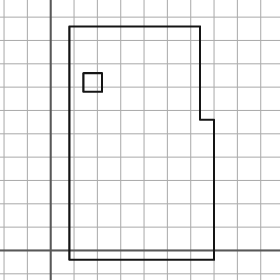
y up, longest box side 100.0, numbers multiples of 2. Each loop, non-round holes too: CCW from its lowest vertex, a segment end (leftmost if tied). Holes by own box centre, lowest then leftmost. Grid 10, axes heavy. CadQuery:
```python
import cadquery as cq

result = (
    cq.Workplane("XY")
    .moveTo(8.0, -4.0)
    .lineTo(70.0, -4.0)
    .lineTo(70.0, 56.0)
    .lineTo(64.0, 56.0)
    .lineTo(64.0, 96.0)
    .lineTo(8.0, 96.0)
    .close()
    .moveTo(14.0, 68.0)
    .lineTo(22.0, 68.0)
    .lineTo(22.0, 76.0)
    .lineTo(14.0, 76.0)
    .close()
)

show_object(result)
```